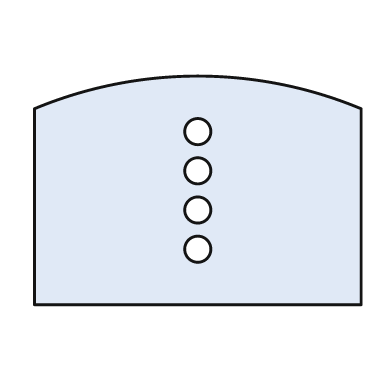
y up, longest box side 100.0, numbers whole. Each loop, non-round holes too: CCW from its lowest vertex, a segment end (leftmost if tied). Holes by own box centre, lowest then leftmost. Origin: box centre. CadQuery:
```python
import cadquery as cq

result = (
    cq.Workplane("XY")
    .moveTo(-50.0, -35.0)
    .lineTo(50.0, -35.0)
    .lineTo(50.0, 25.0)
    .threePointArc((0.0, 35.0), (-50.0, 25.0))
    .close()
    .moveTo(0.0, -18.0)
    .circle(4.0)
    .moveTo(0.0, -6.0)
    .circle(4.0)
    .moveTo(0.0, 6.0)
    .circle(4.0)
    .moveTo(0.0, 18.0)
    .circle(4.0)
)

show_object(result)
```